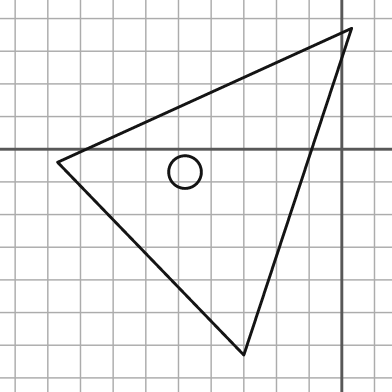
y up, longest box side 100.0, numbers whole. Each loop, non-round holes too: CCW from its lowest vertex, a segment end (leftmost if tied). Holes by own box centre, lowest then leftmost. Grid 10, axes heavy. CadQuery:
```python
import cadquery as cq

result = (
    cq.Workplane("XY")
    .moveTo(-30.0, -63.0)
    .lineTo(3.0, 37.0)
    .lineTo(-87.0, -4.0)
    .close()
    .moveTo(-48.0, -7.0)
    .circle(5.0)
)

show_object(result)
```